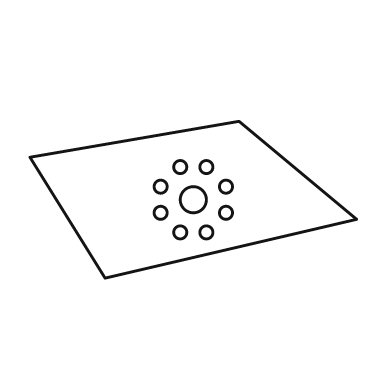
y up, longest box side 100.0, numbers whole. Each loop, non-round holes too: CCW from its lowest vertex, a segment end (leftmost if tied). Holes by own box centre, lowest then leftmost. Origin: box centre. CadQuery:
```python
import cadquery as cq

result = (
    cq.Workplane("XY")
    .moveTo(-27.0, -24.0)
    .lineTo(50.0, -6.0)
    .lineTo(14.0, 24.0)
    .lineTo(-50.0, 13.0)
    .close()
    .moveTo(-4.0, -10.0)
    .circle(2.0)
    .moveTo(4.0, -10.0)
    .circle(2.0)
    .moveTo(-10.0, -4.0)
    .circle(2.0)
    .moveTo(10.0, -4.0)
    .circle(2.0)
    .moveTo(0.0, 0.0)
    .circle(4.0)
    .moveTo(-10.0, 4.0)
    .circle(2.0)
    .moveTo(10.0, 4.0)
    .circle(2.0)
    .moveTo(-4.0, 10.0)
    .circle(2.0)
    .moveTo(4.0, 10.0)
    .circle(2.0)
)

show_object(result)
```